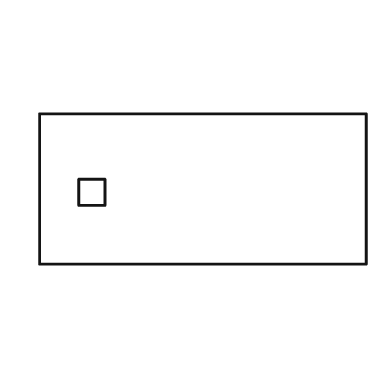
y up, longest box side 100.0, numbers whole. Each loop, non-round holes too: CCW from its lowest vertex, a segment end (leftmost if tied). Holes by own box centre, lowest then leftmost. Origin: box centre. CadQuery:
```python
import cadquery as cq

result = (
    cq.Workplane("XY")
    .moveTo(-50.0, -23.0)
    .lineTo(50.0, -23.0)
    .lineTo(50.0, 23.0)
    .lineTo(-50.0, 23.0)
    .close()
    .moveTo(-38.0, -5.0)
    .lineTo(-30.0, -5.0)
    .lineTo(-30.0, 3.0)
    .lineTo(-38.0, 3.0)
    .close()
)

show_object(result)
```